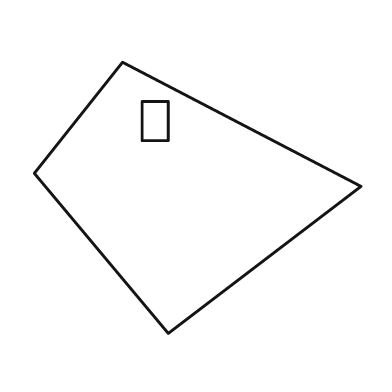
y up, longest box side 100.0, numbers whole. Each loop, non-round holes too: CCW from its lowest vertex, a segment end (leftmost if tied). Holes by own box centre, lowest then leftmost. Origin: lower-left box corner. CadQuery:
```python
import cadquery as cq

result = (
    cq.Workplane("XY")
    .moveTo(41.0, 0.0)
    .lineTo(100.0, 45.0)
    .lineTo(27.0, 83.0)
    .lineTo(0.0, 49.0)
    .close()
    .moveTo(33.0, 59.0)
    .lineTo(41.0, 59.0)
    .lineTo(41.0, 71.0)
    .lineTo(33.0, 71.0)
    .close()
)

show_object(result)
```